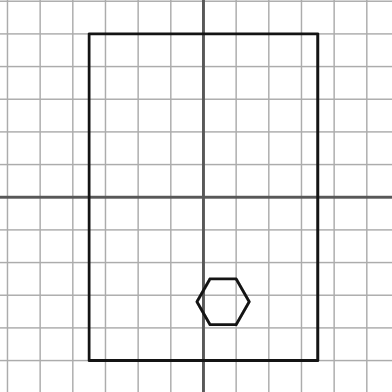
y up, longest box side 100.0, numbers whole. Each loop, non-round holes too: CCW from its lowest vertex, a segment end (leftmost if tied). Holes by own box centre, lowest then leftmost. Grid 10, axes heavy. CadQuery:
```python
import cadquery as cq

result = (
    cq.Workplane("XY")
    .moveTo(-35.0, -50.0)
    .lineTo(35.0, -50.0)
    .lineTo(35.0, 50.0)
    .lineTo(-35.0, 50.0)
    .close()
    .moveTo(2.0, -39.0)
    .lineTo(10.0, -39.0)
    .lineTo(14.0, -32.0)
    .lineTo(10.0, -25.0)
    .lineTo(2.0, -25.0)
    .lineTo(-2.0, -32.0)
    .close()
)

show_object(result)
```